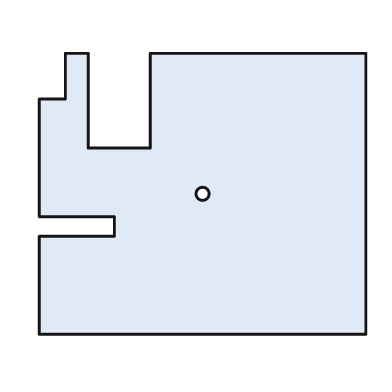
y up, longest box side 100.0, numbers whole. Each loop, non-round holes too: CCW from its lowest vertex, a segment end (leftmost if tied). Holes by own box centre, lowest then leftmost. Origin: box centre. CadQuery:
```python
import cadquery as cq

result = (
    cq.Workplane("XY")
    .moveTo(-50.0, -43.0)
    .lineTo(50.0, -43.0)
    .lineTo(50.0, 43.0)
    .lineTo(-16.0, 43.0)
    .lineTo(-16.0, 14.0)
    .lineTo(-35.0, 14.0)
    .lineTo(-35.0, 43.0)
    .lineTo(-42.0, 43.0)
    .lineTo(-42.0, 29.0)
    .lineTo(-50.0, 29.0)
    .lineTo(-50.0, -7.0)
    .lineTo(-27.0, -7.0)
    .lineTo(-27.0, -13.0)
    .lineTo(-50.0, -13.0)
    .close()
    .moveTo(0.0, 0.0)
    .circle(2.0)
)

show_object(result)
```